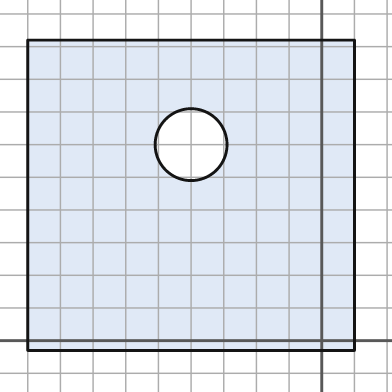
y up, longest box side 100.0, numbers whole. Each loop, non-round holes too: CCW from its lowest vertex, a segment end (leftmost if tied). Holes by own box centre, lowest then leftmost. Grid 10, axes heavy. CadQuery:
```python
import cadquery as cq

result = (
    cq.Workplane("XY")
    .moveTo(-90.0, -3.0)
    .lineTo(10.0, -3.0)
    .lineTo(10.0, 92.0)
    .lineTo(-90.0, 92.0)
    .close()
    .moveTo(-40.0, 60.0)
    .circle(11.0)
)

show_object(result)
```